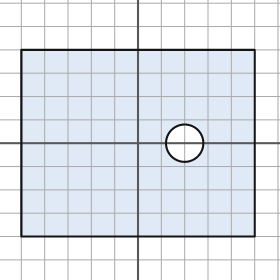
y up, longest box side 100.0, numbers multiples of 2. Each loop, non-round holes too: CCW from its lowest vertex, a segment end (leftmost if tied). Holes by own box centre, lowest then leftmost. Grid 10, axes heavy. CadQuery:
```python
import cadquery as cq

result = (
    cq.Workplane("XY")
    .moveTo(-50.0, -40.0)
    .lineTo(50.0, -40.0)
    .lineTo(50.0, 40.0)
    .lineTo(-50.0, 40.0)
    .close()
    .moveTo(20.0, 0.0)
    .circle(8.0)
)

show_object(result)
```